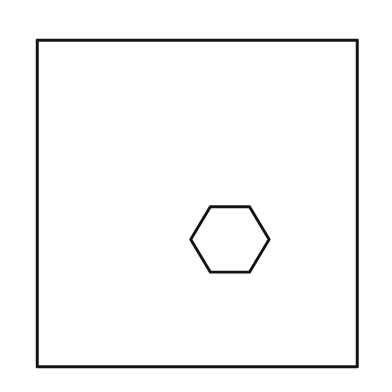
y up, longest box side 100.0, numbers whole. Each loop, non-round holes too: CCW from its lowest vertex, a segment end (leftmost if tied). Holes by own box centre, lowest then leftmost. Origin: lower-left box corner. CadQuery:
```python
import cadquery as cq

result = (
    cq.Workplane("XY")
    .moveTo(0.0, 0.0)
    .lineTo(98.0, 0.0)
    .lineTo(98.0, 100.0)
    .lineTo(0.0, 100.0)
    .close()
    .moveTo(53.0, 29.0)
    .lineTo(65.0, 29.0)
    .lineTo(71.0, 39.0)
    .lineTo(65.0, 49.0)
    .lineTo(53.0, 49.0)
    .lineTo(47.0, 39.0)
    .close()
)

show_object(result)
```